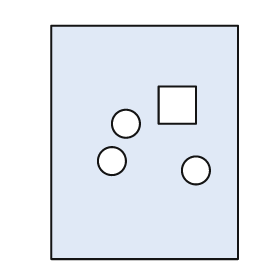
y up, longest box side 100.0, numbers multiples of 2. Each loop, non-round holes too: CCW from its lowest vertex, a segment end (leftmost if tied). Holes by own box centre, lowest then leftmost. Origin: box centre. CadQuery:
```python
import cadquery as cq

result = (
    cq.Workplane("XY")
    .moveTo(-40.0, -50.0)
    .lineTo(40.0, -50.0)
    .lineTo(40.0, 50.0)
    .lineTo(-40.0, 50.0)
    .close()
    .moveTo(22.0, -12.0)
    .circle(6.0)
    .moveTo(-14.0, -8.0)
    .circle(6.0)
    .moveTo(-8.0, 8.0)
    .circle(6.0)
    .moveTo(6.0, 8.0)
    .lineTo(22.0, 8.0)
    .lineTo(22.0, 24.0)
    .lineTo(6.0, 24.0)
    .close()
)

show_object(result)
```